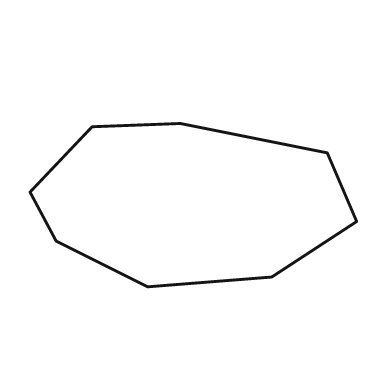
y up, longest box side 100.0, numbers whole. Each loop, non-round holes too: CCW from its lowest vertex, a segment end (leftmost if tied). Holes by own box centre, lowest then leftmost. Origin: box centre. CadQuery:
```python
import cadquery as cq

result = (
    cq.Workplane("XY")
    .moveTo(-14.0, -25.0)
    .lineTo(24.0, -22.0)
    .lineTo(50.0, -5.0)
    .lineTo(41.0, 16.0)
    .lineTo(-4.0, 25.0)
    .lineTo(-31.0, 24.0)
    .lineTo(-50.0, 4.0)
    .lineTo(-42.0, -11.0)
    .close()
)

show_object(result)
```